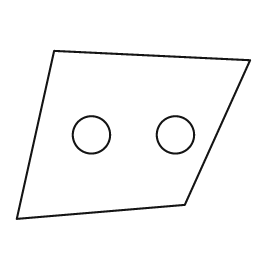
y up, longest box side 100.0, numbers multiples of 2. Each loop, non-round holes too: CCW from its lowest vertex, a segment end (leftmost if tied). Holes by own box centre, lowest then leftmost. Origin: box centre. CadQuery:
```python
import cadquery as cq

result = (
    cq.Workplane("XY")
    .moveTo(-50.0, -36.0)
    .lineTo(22.0, -30.0)
    .lineTo(50.0, 32.0)
    .lineTo(-34.0, 36.0)
    .close()
    .moveTo(-18.0, 0.0)
    .circle(8.0)
    .moveTo(18.0, 0.0)
    .circle(8.0)
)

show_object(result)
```